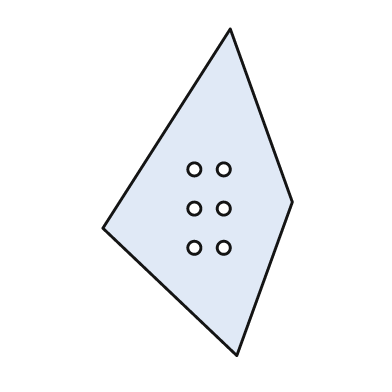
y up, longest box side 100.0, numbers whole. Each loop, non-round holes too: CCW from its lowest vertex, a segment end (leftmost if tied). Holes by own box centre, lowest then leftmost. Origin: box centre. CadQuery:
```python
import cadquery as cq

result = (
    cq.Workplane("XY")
    .moveTo(12.0, -50.0)
    .lineTo(29.0, -3.0)
    .lineTo(10.0, 50.0)
    .lineTo(-29.0, -11.0)
    .close()
    .moveTo(-1.0, -17.0)
    .circle(2.0)
    .moveTo(8.0, -17.0)
    .circle(2.0)
    .moveTo(-1.0, -5.0)
    .circle(2.0)
    .moveTo(8.0, -5.0)
    .circle(2.0)
    .moveTo(-1.0, 7.0)
    .circle(2.0)
    .moveTo(8.0, 7.0)
    .circle(2.0)
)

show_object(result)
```